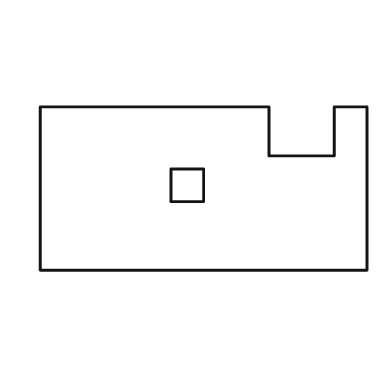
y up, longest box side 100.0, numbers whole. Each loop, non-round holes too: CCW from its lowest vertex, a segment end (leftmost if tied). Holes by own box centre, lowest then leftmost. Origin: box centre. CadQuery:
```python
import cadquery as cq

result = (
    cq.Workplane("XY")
    .moveTo(-50.0, -25.0)
    .lineTo(50.0, -25.0)
    .lineTo(50.0, 25.0)
    .lineTo(40.0, 25.0)
    .lineTo(40.0, 10.0)
    .lineTo(20.0, 10.0)
    .lineTo(20.0, 25.0)
    .lineTo(-50.0, 25.0)
    .close()
    .moveTo(-10.0, -4.0)
    .lineTo(0.0, -4.0)
    .lineTo(0.0, 6.0)
    .lineTo(-10.0, 6.0)
    .close()
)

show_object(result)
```